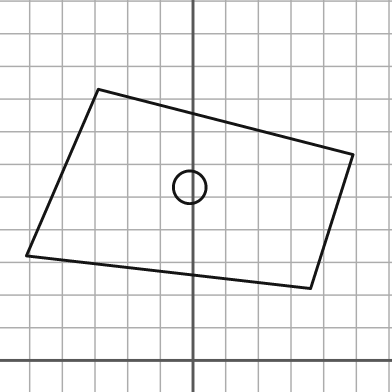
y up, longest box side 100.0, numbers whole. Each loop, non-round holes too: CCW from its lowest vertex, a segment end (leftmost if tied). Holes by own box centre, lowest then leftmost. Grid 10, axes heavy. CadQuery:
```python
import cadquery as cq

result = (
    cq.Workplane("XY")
    .moveTo(36.0, 22.0)
    .lineTo(49.0, 63.0)
    .lineTo(-29.0, 83.0)
    .lineTo(-51.0, 32.0)
    .close()
    .moveTo(-1.0, 53.0)
    .circle(5.0)
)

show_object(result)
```